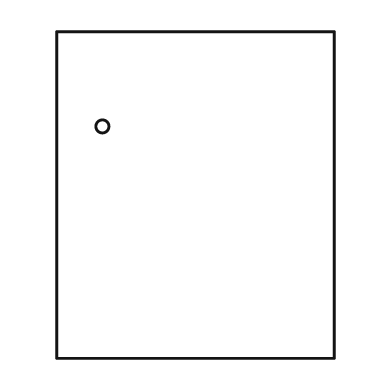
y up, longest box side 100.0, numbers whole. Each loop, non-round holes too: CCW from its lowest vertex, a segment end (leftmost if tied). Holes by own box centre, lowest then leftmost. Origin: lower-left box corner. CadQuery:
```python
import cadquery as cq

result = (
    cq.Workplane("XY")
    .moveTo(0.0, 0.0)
    .lineTo(85.0, 0.0)
    .lineTo(85.0, 100.0)
    .lineTo(0.0, 100.0)
    .close()
    .moveTo(14.0, 71.0)
    .circle(2.0)
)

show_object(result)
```